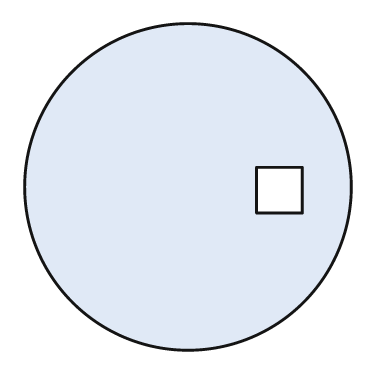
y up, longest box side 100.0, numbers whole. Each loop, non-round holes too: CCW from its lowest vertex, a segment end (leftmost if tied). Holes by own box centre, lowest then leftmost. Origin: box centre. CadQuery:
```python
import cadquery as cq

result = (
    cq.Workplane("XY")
    .moveTo(0.0, 0.0)
    .circle(50.0)
    .moveTo(21.0, -8.0)
    .lineTo(35.0, -8.0)
    .lineTo(35.0, 6.0)
    .lineTo(21.0, 6.0)
    .close()
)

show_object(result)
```